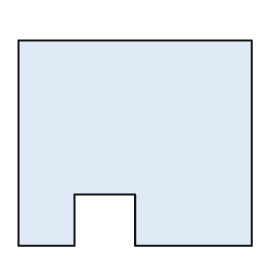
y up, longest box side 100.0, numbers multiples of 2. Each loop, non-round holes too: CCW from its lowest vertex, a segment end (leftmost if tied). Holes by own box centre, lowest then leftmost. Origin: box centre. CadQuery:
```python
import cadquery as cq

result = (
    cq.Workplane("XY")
    .moveTo(-50.0, -44.0)
    .lineTo(-26.0, -44.0)
    .lineTo(-26.0, -22.0)
    .lineTo(0.0, -22.0)
    .lineTo(0.0, -44.0)
    .lineTo(50.0, -44.0)
    .lineTo(50.0, 44.0)
    .lineTo(-50.0, 44.0)
    .close()
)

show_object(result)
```